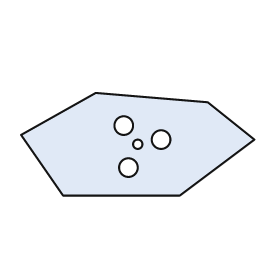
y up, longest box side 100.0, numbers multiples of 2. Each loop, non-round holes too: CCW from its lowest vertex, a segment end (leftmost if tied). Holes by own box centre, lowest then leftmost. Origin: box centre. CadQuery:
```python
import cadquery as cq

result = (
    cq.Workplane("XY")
    .moveTo(-32.0, -22.0)
    .lineTo(18.0, -22.0)
    .lineTo(50.0, 2.0)
    .lineTo(30.0, 18.0)
    .lineTo(-18.0, 22.0)
    .lineTo(-50.0, 4.0)
    .close()
    .moveTo(-4.0, -10.0)
    .circle(4.0)
    .moveTo(0.0, 0.0)
    .circle(2.0)
    .moveTo(10.0, 2.0)
    .circle(4.0)
    .moveTo(-6.0, 8.0)
    .circle(4.0)
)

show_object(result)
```